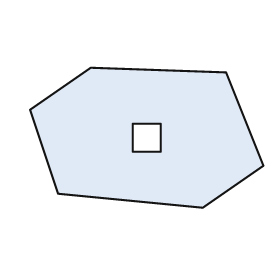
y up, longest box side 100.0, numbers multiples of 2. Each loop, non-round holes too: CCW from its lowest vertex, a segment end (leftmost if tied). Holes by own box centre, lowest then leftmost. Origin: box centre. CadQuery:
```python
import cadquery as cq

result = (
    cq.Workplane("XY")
    .moveTo(24.0, -30.0)
    .lineTo(50.0, -12.0)
    .lineTo(34.0, 28.0)
    .lineTo(-24.0, 30.0)
    .lineTo(-50.0, 12.0)
    .lineTo(-38.0, -24.0)
    .close()
    .moveTo(-6.0, -6.0)
    .lineTo(6.0, -6.0)
    .lineTo(6.0, 6.0)
    .lineTo(-6.0, 6.0)
    .close()
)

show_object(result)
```